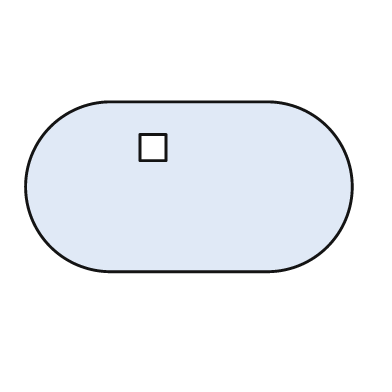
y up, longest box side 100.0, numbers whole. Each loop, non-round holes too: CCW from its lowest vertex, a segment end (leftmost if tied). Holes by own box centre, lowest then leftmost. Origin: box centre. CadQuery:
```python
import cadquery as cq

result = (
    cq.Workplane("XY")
    .moveTo(-24.0, -26.0)
    .lineTo(24.0, -26.0)
    .threePointArc((50.0, 0.0), (24.0, 26.0))
    .lineTo(-24.0, 26.0)
    .threePointArc((-50.0, 0.0), (-24.0, -26.0))
    .close()
    .moveTo(-15.0, 8.0)
    .lineTo(-7.0, 8.0)
    .lineTo(-7.0, 16.0)
    .lineTo(-15.0, 16.0)
    .close()
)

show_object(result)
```